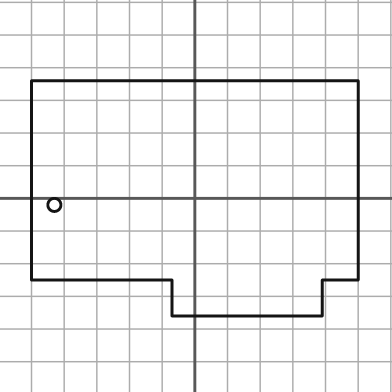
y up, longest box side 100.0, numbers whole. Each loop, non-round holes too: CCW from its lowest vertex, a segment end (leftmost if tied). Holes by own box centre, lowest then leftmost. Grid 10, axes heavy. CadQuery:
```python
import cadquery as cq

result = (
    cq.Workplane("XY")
    .moveTo(-7.0, -36.0)
    .lineTo(39.0, -36.0)
    .lineTo(39.0, -25.0)
    .lineTo(50.0, -25.0)
    .lineTo(50.0, 36.0)
    .lineTo(-50.0, 36.0)
    .lineTo(-50.0, -25.0)
    .lineTo(-7.0, -25.0)
    .close()
    .moveTo(-43.0, -2.0)
    .circle(2.0)
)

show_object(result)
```